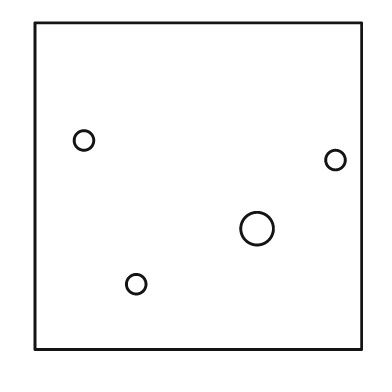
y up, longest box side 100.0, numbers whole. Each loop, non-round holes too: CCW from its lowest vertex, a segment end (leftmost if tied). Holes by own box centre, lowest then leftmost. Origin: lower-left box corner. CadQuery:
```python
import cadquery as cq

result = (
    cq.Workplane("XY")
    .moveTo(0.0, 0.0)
    .lineTo(100.0, 0.0)
    .lineTo(100.0, 100.0)
    .lineTo(0.0, 100.0)
    .close()
    .moveTo(31.0, 20.0)
    .circle(3.0)
    .moveTo(68.0, 37.0)
    .circle(5.0)
    .moveTo(92.0, 58.0)
    .circle(3.0)
    .moveTo(15.0, 64.0)
    .circle(3.0)
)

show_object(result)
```